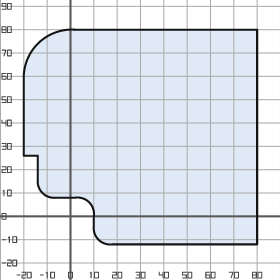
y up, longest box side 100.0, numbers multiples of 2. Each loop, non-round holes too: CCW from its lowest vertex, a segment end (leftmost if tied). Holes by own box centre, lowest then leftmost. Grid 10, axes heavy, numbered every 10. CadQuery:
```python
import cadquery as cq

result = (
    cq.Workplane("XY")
    .moveTo(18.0, -12.0)
    .lineTo(80.0, -12.0)
    .lineTo(80.0, 80.0)
    .lineTo(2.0, 80.0)
    .threePointArc((-14.0, 74.0), (-20.0, 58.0))
    .lineTo(-20.0, 26.0)
    .lineTo(-14.0, 26.0)
    .lineTo(-14.0, 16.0)
    .threePointArc((-12.0, 10.0), (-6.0, 8.0))
    .lineTo(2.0, 8.0)
    .threePointArc((8.0, 6.0), (10.0, 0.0))
    .lineTo(10.0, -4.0)
    .threePointArc((12.0, -10.0), (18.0, -12.0))
    .close()
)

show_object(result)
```